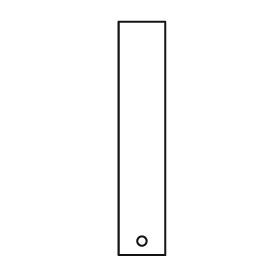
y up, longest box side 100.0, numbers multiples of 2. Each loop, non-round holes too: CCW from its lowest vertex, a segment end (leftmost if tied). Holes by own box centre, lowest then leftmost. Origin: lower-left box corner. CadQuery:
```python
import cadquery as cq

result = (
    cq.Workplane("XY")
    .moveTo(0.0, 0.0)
    .lineTo(20.0, 0.0)
    .lineTo(20.0, 100.0)
    .lineTo(0.0, 100.0)
    .close()
    .moveTo(10.0, 6.0)
    .circle(2.0)
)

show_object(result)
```